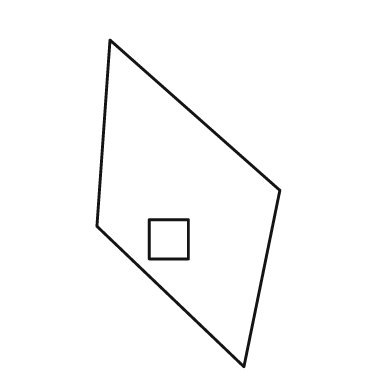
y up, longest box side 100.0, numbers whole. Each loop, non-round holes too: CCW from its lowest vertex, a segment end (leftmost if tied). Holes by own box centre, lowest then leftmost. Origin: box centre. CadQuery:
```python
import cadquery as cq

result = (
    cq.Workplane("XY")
    .moveTo(17.0, -50.0)
    .lineTo(28.0, 4.0)
    .lineTo(-24.0, 50.0)
    .lineTo(-28.0, -7.0)
    .close()
    .moveTo(-12.0, -17.0)
    .lineTo(0.0, -17.0)
    .lineTo(0.0, -5.0)
    .lineTo(-12.0, -5.0)
    .close()
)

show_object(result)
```